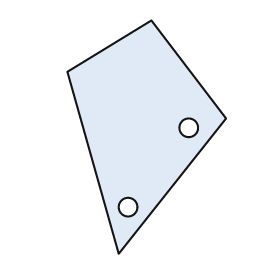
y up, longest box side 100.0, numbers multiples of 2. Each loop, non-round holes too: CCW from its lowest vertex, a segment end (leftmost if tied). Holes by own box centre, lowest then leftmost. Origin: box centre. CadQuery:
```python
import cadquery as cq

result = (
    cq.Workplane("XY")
    .moveTo(-12.0, -50.0)
    .lineTo(34.0, 8.0)
    .lineTo(2.0, 50.0)
    .lineTo(-34.0, 28.0)
    .close()
    .moveTo(-8.0, -30.0)
    .circle(4.0)
    .moveTo(18.0, 4.0)
    .circle(4.0)
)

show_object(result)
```